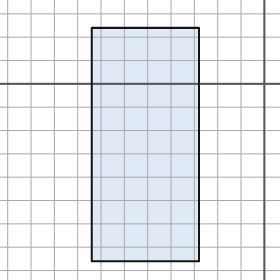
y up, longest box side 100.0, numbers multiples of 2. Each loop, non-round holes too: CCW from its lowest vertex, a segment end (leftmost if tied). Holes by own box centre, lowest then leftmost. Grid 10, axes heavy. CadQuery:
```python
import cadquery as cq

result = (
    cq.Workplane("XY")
    .moveTo(-74.0, -76.0)
    .lineTo(-28.0, -76.0)
    .lineTo(-28.0, 24.0)
    .lineTo(-74.0, 24.0)
    .close()
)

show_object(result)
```